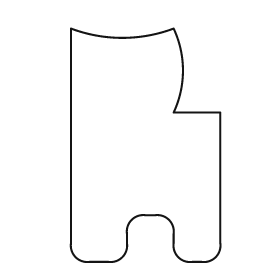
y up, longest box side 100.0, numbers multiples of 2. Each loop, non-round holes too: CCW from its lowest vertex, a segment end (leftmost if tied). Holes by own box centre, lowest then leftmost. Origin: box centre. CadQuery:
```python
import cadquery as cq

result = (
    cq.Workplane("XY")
    .moveTo(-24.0, -50.0)
    .lineTo(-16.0, -50.0)
    .threePointArc((-10.0, -48.0), (-8.0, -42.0))
    .lineTo(-8.0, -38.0)
    .threePointArc((-6.0, -32.0), (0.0, -30.0))
    .lineTo(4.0, -30.0)
    .threePointArc((10.0, -32.0), (12.0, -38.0))
    .lineTo(12.0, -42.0)
    .threePointArc((14.0, -48.0), (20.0, -50.0))
    .lineTo(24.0, -50.0)
    .threePointArc((30.0, -48.0), (32.0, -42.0))
    .lineTo(32.0, 14.0)
    .lineTo(12.0, 14.0)
    .threePointArc((16.0, 32.0), (12.0, 50.0))
    .threePointArc((-10.0, 46.0), (-32.0, 50.0))
    .lineTo(-32.0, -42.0)
    .threePointArc((-30.0, -48.0), (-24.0, -50.0))
    .close()
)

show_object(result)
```